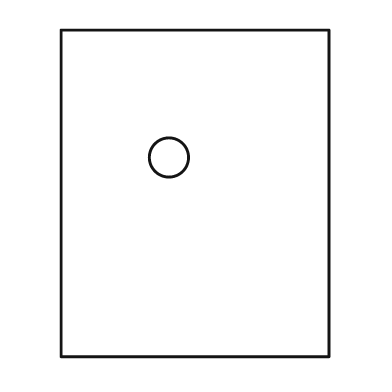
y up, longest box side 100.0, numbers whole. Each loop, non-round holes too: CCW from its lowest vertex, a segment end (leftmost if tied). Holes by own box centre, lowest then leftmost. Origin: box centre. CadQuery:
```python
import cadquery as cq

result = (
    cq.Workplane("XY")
    .moveTo(-41.0, -50.0)
    .lineTo(41.0, -50.0)
    .lineTo(41.0, 50.0)
    .lineTo(-41.0, 50.0)
    .close()
    .moveTo(-8.0, 11.0)
    .circle(6.0)
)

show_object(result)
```